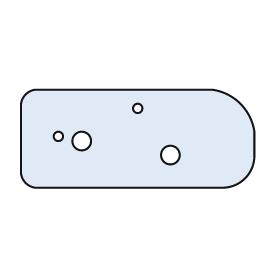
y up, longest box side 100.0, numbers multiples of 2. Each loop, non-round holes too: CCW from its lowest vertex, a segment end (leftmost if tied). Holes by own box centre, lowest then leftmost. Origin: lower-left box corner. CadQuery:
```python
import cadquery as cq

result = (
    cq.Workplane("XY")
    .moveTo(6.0, 0.0)
    .lineTo(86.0, 0.0)
    .threePointArc((96.0, 4.0), (100.0, 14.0))
    .lineTo(100.0, 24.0)
    .threePointArc((94.0, 36.0), (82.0, 42.0))
    .lineTo(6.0, 42.0)
    .threePointArc((2.0, 40.0), (0.0, 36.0))
    .lineTo(0.0, 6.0)
    .threePointArc((2.0, 2.0), (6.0, 0.0))
    .close()
    .moveTo(64.0, 14.0)
    .circle(4.0)
    .moveTo(26.0, 20.0)
    .circle(4.0)
    .moveTo(16.0, 22.0)
    .circle(2.0)
    .moveTo(50.0, 34.0)
    .circle(2.0)
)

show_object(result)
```